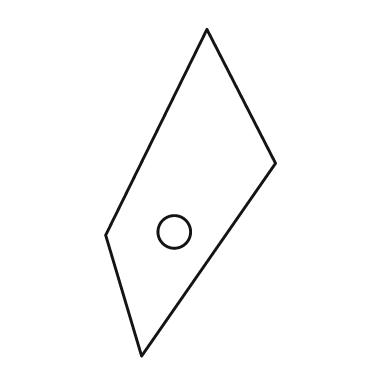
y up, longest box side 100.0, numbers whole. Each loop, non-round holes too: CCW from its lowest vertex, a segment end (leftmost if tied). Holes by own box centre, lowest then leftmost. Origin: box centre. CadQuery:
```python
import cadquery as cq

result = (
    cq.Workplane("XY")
    .moveTo(-15.0, -50.0)
    .lineTo(26.0, 9.0)
    .lineTo(5.0, 50.0)
    .lineTo(-26.0, -13.0)
    .close()
    .moveTo(-5.0, -12.0)
    .circle(5.0)
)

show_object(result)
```